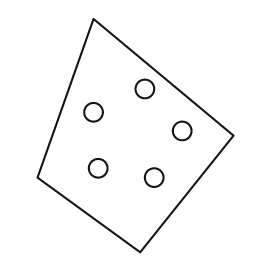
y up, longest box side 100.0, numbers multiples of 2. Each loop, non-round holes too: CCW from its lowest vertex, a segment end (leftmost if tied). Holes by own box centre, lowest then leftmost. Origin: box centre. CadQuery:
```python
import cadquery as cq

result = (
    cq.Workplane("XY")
    .moveTo(2.0, -50.0)
    .lineTo(42.0, 0.0)
    .lineTo(-18.0, 50.0)
    .lineTo(-42.0, -18.0)
    .close()
    .moveTo(8.0, -18.0)
    .circle(4.0)
    .moveTo(-16.0, -14.0)
    .circle(4.0)
    .moveTo(20.0, 2.0)
    .circle(4.0)
    .moveTo(-18.0, 10.0)
    .circle(4.0)
    .moveTo(4.0, 20.0)
    .circle(4.0)
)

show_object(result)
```